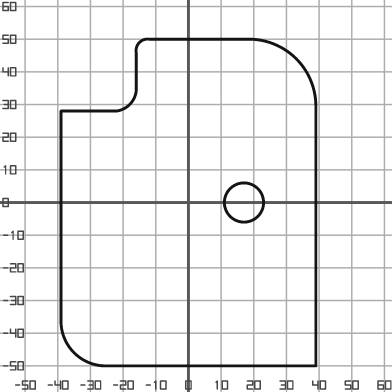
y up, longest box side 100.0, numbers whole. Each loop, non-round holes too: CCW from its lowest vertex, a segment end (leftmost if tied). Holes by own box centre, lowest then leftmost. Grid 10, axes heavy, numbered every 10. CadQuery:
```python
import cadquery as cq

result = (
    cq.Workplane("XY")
    .moveTo(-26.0, -50.0)
    .lineTo(39.0, -50.0)
    .lineTo(39.0, 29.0)
    .threePointArc((33.0, 44.0), (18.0, 50.0))
    .lineTo(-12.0, 50.0)
    .threePointArc((-15.0, 49.0), (-16.0, 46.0))
    .lineTo(-16.0, 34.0)
    .threePointArc((-18.0, 30.0), (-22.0, 28.0))
    .lineTo(-39.0, 28.0)
    .lineTo(-39.0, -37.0)
    .threePointArc((-35.0, -46.0), (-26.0, -50.0))
    .close()
    .moveTo(17.0, 0.0)
    .circle(6.0)
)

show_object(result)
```